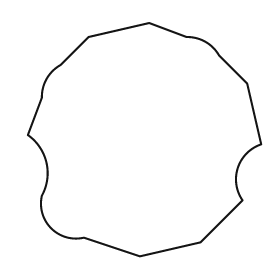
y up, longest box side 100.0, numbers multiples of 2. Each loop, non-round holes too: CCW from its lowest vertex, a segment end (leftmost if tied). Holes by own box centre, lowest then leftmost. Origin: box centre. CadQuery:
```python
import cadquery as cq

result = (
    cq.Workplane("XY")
    .moveTo(-2.0, -50.0)
    .lineTo(24.0, -44.0)
    .lineTo(42.0, -26.0)
    .threePointArc((40.0, -12.0), (50.0, -2.0))
    .lineTo(44.0, 24.0)
    .lineTo(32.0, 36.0)
    .threePointArc((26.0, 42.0), (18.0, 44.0))
    .lineTo(2.0, 50.0)
    .lineTo(-24.0, 44.0)
    .lineTo(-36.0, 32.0)
    .threePointArc((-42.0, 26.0), (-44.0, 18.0))
    .lineTo(-50.0, 2.0)
    .threePointArc((-42.0, -10.0), (-44.0, -24.0))
    .threePointArc((-40.0, -38.0), (-26.0, -42.0))
    .close()
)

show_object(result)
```